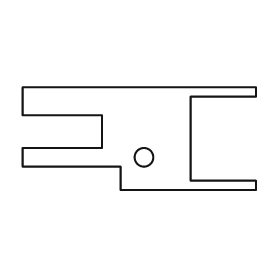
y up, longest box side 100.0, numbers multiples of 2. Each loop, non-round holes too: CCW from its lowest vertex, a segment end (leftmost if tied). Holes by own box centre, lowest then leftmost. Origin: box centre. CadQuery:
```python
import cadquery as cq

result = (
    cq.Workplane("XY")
    .moveTo(-8.0, -22.0)
    .lineTo(50.0, -22.0)
    .lineTo(50.0, -18.0)
    .lineTo(22.0, -18.0)
    .lineTo(22.0, 18.0)
    .lineTo(50.0, 18.0)
    .lineTo(50.0, 22.0)
    .lineTo(-50.0, 22.0)
    .lineTo(-50.0, 10.0)
    .lineTo(-16.0, 10.0)
    .lineTo(-16.0, -4.0)
    .lineTo(-50.0, -4.0)
    .lineTo(-50.0, -12.0)
    .lineTo(-8.0, -12.0)
    .close()
    .moveTo(2.0, -8.0)
    .circle(4.0)
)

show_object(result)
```